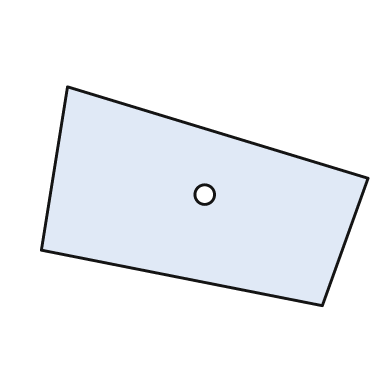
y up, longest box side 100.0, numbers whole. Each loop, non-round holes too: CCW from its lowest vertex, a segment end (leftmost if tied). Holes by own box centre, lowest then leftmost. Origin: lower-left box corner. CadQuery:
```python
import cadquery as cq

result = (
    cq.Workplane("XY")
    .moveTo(86.0, 0.0)
    .lineTo(100.0, 39.0)
    .lineTo(8.0, 67.0)
    .lineTo(0.0, 17.0)
    .close()
    .moveTo(50.0, 34.0)
    .circle(3.0)
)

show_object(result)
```